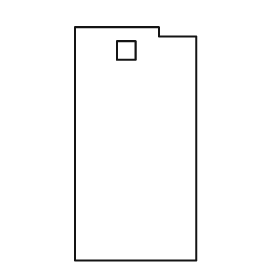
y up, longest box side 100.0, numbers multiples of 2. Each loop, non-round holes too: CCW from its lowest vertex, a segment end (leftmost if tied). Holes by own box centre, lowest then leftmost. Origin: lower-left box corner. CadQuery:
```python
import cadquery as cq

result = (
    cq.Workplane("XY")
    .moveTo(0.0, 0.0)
    .lineTo(52.0, 0.0)
    .lineTo(52.0, 96.0)
    .lineTo(36.0, 96.0)
    .lineTo(36.0, 100.0)
    .lineTo(0.0, 100.0)
    .close()
    .moveTo(18.0, 86.0)
    .lineTo(26.0, 86.0)
    .lineTo(26.0, 94.0)
    .lineTo(18.0, 94.0)
    .close()
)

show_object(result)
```